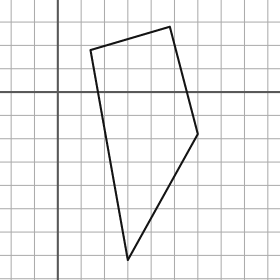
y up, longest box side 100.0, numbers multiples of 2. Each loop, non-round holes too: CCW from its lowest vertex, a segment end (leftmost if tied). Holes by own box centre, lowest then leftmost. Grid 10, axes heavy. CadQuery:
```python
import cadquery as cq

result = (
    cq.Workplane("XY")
    .moveTo(30.0, -72.0)
    .lineTo(60.0, -18.0)
    .lineTo(48.0, 28.0)
    .lineTo(14.0, 18.0)
    .close()
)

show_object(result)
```